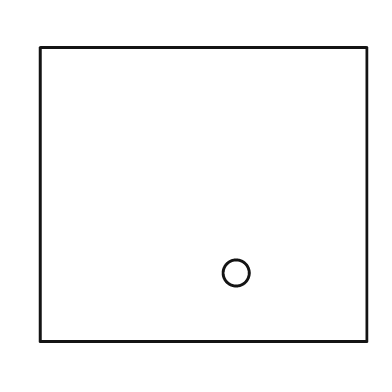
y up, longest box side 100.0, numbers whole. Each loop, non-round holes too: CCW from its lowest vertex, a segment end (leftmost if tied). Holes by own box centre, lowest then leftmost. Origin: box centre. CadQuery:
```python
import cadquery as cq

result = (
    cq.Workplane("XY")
    .moveTo(-50.0, -45.0)
    .lineTo(50.0, -45.0)
    .lineTo(50.0, 45.0)
    .lineTo(-50.0, 45.0)
    .close()
    .moveTo(10.0, -24.0)
    .circle(4.0)
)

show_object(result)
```